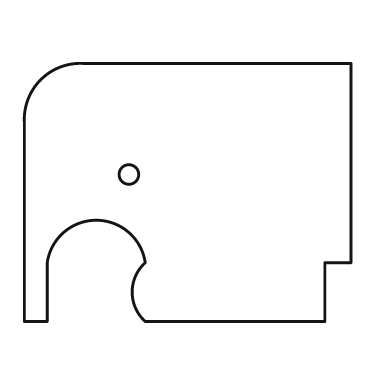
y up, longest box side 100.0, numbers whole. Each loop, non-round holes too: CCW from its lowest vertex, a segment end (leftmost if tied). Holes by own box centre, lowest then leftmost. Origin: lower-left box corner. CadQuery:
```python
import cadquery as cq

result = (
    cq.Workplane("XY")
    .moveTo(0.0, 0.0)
    .lineTo(7.0, 0.0)
    .lineTo(7.0, 18.0)
    .threePointArc((22.0, 31.0), (37.0, 18.0))
    .threePointArc((33.0, 9.0), (37.0, 0.0))
    .lineTo(92.0, 0.0)
    .lineTo(92.0, 18.0)
    .lineTo(100.0, 18.0)
    .lineTo(100.0, 79.0)
    .lineTo(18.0, 79.0)
    .threePointArc((5.0, 74.0), (0.0, 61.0))
    .close()
    .moveTo(32.0, 45.0)
    .circle(3.0)
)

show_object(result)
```